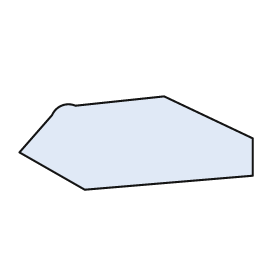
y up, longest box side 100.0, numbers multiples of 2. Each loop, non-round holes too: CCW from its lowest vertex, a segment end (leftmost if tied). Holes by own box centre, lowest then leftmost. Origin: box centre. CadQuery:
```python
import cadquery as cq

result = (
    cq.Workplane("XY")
    .moveTo(-22.0, -20.0)
    .lineTo(50.0, -14.0)
    .lineTo(50.0, 2.0)
    .lineTo(12.0, 20.0)
    .lineTo(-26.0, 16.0)
    .threePointArc((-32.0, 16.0), (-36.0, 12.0))
    .lineTo(-50.0, -4.0)
    .close()
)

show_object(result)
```